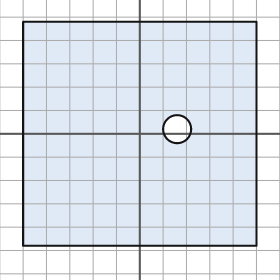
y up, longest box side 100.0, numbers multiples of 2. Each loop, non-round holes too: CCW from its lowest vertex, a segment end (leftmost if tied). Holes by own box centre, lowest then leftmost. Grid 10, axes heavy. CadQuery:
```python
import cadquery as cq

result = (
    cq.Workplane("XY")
    .moveTo(-50.0, -48.0)
    .lineTo(50.0, -48.0)
    .lineTo(50.0, 48.0)
    .lineTo(-50.0, 48.0)
    .close()
    .moveTo(16.0, 2.0)
    .circle(6.0)
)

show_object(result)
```